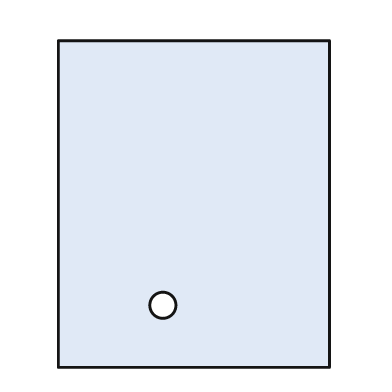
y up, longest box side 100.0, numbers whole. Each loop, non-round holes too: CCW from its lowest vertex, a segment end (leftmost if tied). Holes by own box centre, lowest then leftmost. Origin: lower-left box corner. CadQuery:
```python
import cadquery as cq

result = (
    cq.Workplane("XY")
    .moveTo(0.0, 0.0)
    .lineTo(83.0, 0.0)
    .lineTo(83.0, 100.0)
    .lineTo(0.0, 100.0)
    .close()
    .moveTo(32.0, 19.0)
    .circle(4.0)
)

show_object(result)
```